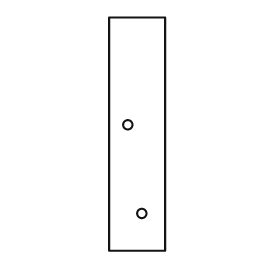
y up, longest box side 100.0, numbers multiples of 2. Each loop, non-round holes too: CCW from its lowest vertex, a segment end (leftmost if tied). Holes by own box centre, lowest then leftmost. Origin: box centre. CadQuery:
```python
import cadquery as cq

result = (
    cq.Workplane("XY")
    .moveTo(-12.0, -50.0)
    .lineTo(12.0, -50.0)
    .lineTo(12.0, 50.0)
    .lineTo(-12.0, 50.0)
    .close()
    .moveTo(2.0, -34.0)
    .circle(2.0)
    .moveTo(-4.0, 4.0)
    .circle(2.0)
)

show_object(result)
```